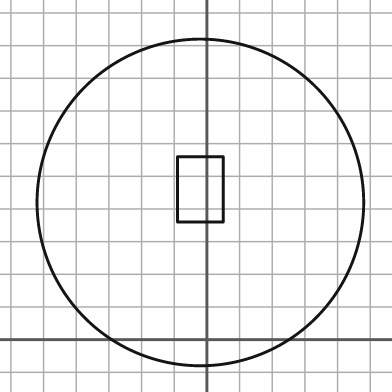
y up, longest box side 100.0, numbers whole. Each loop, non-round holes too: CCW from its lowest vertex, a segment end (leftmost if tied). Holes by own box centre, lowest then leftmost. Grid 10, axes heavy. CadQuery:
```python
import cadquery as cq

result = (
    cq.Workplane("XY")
    .moveTo(-2.0, 42.0)
    .circle(50.0)
    .moveTo(-9.0, 36.0)
    .lineTo(5.0, 36.0)
    .lineTo(5.0, 56.0)
    .lineTo(-9.0, 56.0)
    .close()
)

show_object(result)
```